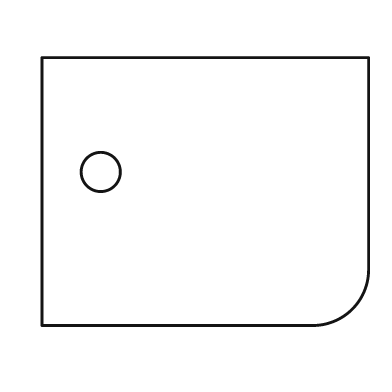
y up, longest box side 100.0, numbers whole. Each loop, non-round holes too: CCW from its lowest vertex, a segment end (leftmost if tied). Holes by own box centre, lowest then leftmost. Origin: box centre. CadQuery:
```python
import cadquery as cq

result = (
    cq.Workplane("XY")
    .moveTo(-50.0, -41.0)
    .lineTo(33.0, -41.0)
    .threePointArc((45.0, -36.0), (50.0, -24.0))
    .lineTo(50.0, 41.0)
    .lineTo(-50.0, 41.0)
    .close()
    .moveTo(-32.0, 6.0)
    .circle(6.0)
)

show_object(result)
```